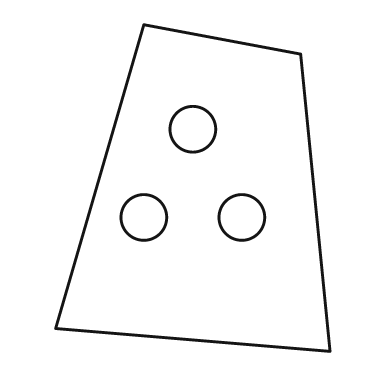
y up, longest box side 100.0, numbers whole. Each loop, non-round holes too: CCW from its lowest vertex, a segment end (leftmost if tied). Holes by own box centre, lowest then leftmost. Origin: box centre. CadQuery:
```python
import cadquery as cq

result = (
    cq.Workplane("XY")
    .moveTo(42.0, -50.0)
    .lineTo(33.0, 41.0)
    .lineTo(-15.0, 50.0)
    .lineTo(-42.0, -43.0)
    .close()
    .moveTo(-15.0, -9.0)
    .circle(7.0)
    .moveTo(15.0, -9.0)
    .circle(7.0)
    .moveTo(0.0, 18.0)
    .circle(7.0)
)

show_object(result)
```